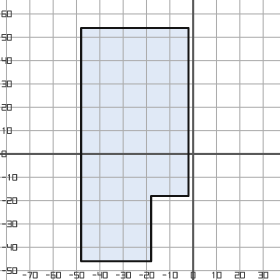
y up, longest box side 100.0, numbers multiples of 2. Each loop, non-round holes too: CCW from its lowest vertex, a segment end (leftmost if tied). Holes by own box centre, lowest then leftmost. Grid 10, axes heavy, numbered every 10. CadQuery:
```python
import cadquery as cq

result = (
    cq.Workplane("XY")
    .moveTo(-48.0, -46.0)
    .lineTo(-18.0, -46.0)
    .lineTo(-18.0, -18.0)
    .lineTo(-2.0, -18.0)
    .lineTo(-2.0, 54.0)
    .lineTo(-48.0, 54.0)
    .close()
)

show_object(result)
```